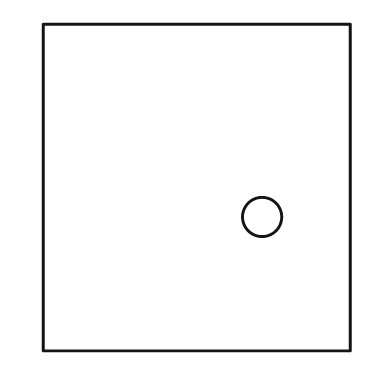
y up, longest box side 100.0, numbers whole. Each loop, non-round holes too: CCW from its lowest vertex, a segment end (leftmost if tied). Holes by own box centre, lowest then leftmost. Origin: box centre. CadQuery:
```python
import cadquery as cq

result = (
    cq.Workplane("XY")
    .moveTo(-47.0, -50.0)
    .lineTo(47.0, -50.0)
    .lineTo(47.0, 50.0)
    .lineTo(-47.0, 50.0)
    .close()
    .moveTo(20.0, -9.0)
    .circle(6.0)
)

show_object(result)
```